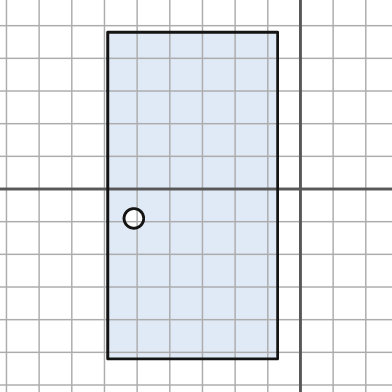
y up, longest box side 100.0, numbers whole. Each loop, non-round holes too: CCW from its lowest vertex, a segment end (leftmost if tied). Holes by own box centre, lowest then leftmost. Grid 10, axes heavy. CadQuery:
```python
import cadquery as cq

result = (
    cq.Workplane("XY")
    .moveTo(-59.0, -52.0)
    .lineTo(-7.0, -52.0)
    .lineTo(-7.0, 48.0)
    .lineTo(-59.0, 48.0)
    .close()
    .moveTo(-51.0, -9.0)
    .circle(3.0)
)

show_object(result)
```